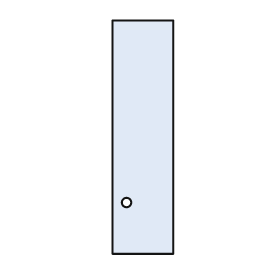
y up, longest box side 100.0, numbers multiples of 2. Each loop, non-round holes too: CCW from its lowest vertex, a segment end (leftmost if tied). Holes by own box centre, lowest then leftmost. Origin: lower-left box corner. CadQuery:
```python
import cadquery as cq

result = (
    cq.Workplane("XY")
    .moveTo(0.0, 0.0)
    .lineTo(26.0, 0.0)
    .lineTo(26.0, 100.0)
    .lineTo(0.0, 100.0)
    .close()
    .moveTo(6.0, 22.0)
    .circle(2.0)
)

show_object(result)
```